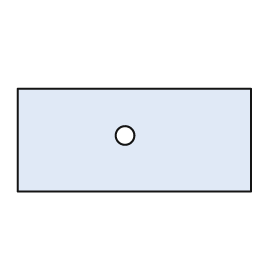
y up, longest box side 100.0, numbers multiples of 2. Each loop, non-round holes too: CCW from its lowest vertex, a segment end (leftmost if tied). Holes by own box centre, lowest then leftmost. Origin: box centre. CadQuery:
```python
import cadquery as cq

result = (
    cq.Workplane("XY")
    .moveTo(-50.0, -22.0)
    .lineTo(50.0, -22.0)
    .lineTo(50.0, 22.0)
    .lineTo(-50.0, 22.0)
    .close()
    .moveTo(-4.0, 2.0)
    .circle(4.0)
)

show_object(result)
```